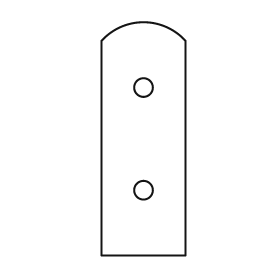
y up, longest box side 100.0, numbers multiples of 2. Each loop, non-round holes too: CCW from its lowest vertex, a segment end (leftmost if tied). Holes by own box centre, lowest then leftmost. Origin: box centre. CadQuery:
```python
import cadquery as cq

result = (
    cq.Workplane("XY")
    .moveTo(-18.0, -50.0)
    .lineTo(18.0, -50.0)
    .lineTo(18.0, 42.0)
    .threePointArc((0.0, 50.0), (-18.0, 42.0))
    .close()
    .moveTo(0.0, -22.0)
    .circle(4.0)
    .moveTo(0.0, 22.0)
    .circle(4.0)
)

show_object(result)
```